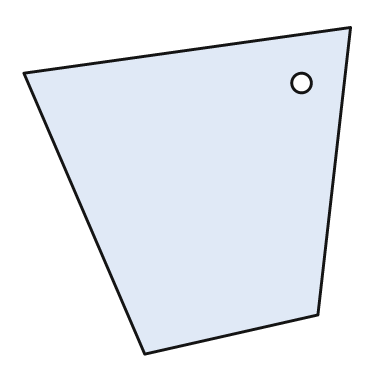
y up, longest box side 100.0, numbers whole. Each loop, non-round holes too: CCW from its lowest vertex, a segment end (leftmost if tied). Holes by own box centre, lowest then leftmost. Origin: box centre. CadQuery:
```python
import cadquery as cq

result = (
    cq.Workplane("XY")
    .moveTo(-13.0, -50.0)
    .lineTo(40.0, -38.0)
    .lineTo(50.0, 50.0)
    .lineTo(-50.0, 36.0)
    .close()
    .moveTo(35.0, 33.0)
    .circle(3.0)
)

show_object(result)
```